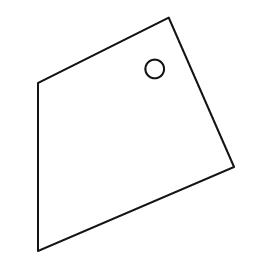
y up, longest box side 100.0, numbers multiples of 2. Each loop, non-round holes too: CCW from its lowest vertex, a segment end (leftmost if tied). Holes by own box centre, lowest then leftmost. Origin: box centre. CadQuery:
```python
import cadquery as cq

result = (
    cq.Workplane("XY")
    .moveTo(-42.0, -50.0)
    .lineTo(42.0, -14.0)
    .lineTo(14.0, 50.0)
    .lineTo(-42.0, 22.0)
    .close()
    .moveTo(8.0, 28.0)
    .circle(4.0)
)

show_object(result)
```